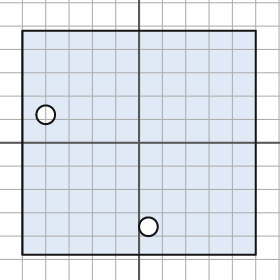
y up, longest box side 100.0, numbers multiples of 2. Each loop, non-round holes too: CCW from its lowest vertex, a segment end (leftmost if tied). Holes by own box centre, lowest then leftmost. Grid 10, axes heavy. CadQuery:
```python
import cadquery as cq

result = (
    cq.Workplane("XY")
    .moveTo(-50.0, -48.0)
    .lineTo(50.0, -48.0)
    .lineTo(50.0, 48.0)
    .lineTo(-50.0, 48.0)
    .close()
    .moveTo(4.0, -36.0)
    .circle(4.0)
    .moveTo(-40.0, 12.0)
    .circle(4.0)
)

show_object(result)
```